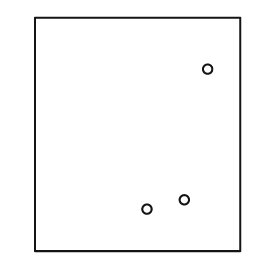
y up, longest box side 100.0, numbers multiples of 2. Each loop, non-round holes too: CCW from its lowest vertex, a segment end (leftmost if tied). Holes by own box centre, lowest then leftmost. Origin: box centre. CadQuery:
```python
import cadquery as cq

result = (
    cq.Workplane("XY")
    .moveTo(-44.0, -50.0)
    .lineTo(44.0, -50.0)
    .lineTo(44.0, 50.0)
    .lineTo(-44.0, 50.0)
    .close()
    .moveTo(4.0, -32.0)
    .circle(2.0)
    .moveTo(20.0, -28.0)
    .circle(2.0)
    .moveTo(30.0, 28.0)
    .circle(2.0)
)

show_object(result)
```